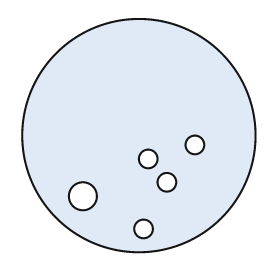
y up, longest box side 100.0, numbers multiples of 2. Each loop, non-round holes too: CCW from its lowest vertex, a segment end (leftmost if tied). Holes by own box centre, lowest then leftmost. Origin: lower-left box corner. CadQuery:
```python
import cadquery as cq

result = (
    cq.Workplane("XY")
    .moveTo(50.0, 50.0)
    .circle(50.0)
    .moveTo(52.0, 10.0)
    .circle(4.0)
    .moveTo(26.0, 24.0)
    .circle(6.0)
    .moveTo(62.0, 30.0)
    .circle(4.0)
    .moveTo(54.0, 40.0)
    .circle(4.0)
    .moveTo(74.0, 46.0)
    .circle(4.0)
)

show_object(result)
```